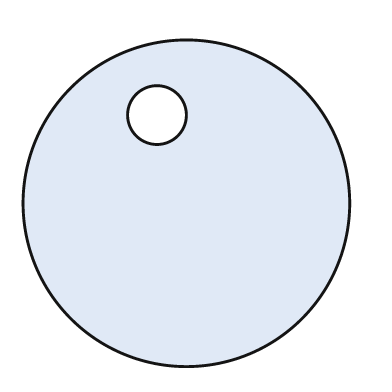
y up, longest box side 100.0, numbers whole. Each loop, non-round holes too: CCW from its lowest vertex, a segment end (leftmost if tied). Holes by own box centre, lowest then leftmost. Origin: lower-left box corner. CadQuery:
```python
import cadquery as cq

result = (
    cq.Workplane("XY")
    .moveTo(50.0, 50.0)
    .circle(50.0)
    .moveTo(41.0, 77.0)
    .circle(9.0)
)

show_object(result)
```